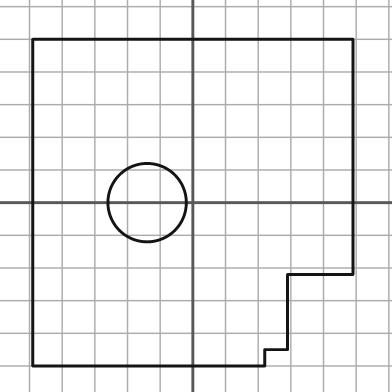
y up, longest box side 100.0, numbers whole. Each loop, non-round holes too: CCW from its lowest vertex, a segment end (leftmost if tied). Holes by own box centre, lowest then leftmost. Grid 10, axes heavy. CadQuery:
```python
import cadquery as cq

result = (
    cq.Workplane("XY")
    .moveTo(-49.0, -50.0)
    .lineTo(22.0, -50.0)
    .lineTo(22.0, -45.0)
    .lineTo(29.0, -45.0)
    .lineTo(29.0, -22.0)
    .lineTo(49.0, -22.0)
    .lineTo(49.0, 50.0)
    .lineTo(-49.0, 50.0)
    .close()
    .moveTo(-14.0, 0.0)
    .circle(12.0)
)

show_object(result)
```